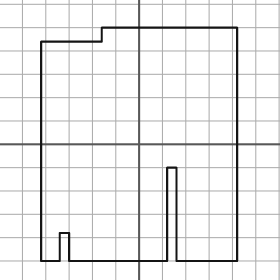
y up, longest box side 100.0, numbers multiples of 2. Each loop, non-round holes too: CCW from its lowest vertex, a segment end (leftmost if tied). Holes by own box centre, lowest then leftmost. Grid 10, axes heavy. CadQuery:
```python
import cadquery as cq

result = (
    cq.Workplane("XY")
    .moveTo(-42.0, -50.0)
    .lineTo(-34.0, -50.0)
    .lineTo(-34.0, -38.0)
    .lineTo(-30.0, -38.0)
    .lineTo(-30.0, -50.0)
    .lineTo(12.0, -50.0)
    .lineTo(12.0, -10.0)
    .lineTo(16.0, -10.0)
    .lineTo(16.0, -50.0)
    .lineTo(42.0, -50.0)
    .lineTo(42.0, 50.0)
    .lineTo(-16.0, 50.0)
    .lineTo(-16.0, 44.0)
    .lineTo(-42.0, 44.0)
    .close()
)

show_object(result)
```